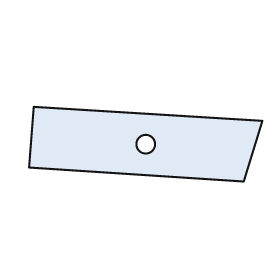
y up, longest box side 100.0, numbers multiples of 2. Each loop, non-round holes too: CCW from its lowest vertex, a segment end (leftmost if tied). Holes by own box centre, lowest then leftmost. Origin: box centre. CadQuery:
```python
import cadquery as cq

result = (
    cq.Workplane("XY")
    .moveTo(42.0, -16.0)
    .lineTo(50.0, 10.0)
    .lineTo(-48.0, 16.0)
    .lineTo(-50.0, -10.0)
    .close()
    .moveTo(0.0, 0.0)
    .circle(4.0)
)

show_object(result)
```